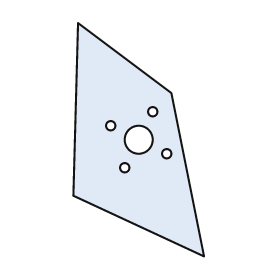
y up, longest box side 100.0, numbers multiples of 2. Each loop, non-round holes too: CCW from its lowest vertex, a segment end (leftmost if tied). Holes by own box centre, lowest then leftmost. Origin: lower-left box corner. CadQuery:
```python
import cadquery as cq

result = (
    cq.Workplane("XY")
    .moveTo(56.0, 0.0)
    .lineTo(42.0, 70.0)
    .lineTo(2.0, 100.0)
    .lineTo(0.0, 26.0)
    .close()
    .moveTo(22.0, 38.0)
    .circle(2.0)
    .moveTo(40.0, 44.0)
    .circle(2.0)
    .moveTo(28.0, 50.0)
    .circle(6.0)
    .moveTo(16.0, 56.0)
    .circle(2.0)
    .moveTo(34.0, 62.0)
    .circle(2.0)
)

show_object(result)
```